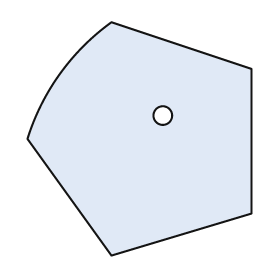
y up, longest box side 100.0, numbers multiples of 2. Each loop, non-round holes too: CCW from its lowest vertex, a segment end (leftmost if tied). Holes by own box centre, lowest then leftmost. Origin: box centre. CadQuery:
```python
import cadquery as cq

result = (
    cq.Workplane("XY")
    .moveTo(-12.0, -50.0)
    .lineTo(48.0, -32.0)
    .lineTo(48.0, 30.0)
    .lineTo(-12.0, 50.0)
    .threePointArc((-34.0, 28.0), (-48.0, 0.0))
    .close()
    .moveTo(10.0, 10.0)
    .circle(4.0)
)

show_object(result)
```